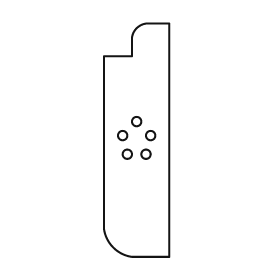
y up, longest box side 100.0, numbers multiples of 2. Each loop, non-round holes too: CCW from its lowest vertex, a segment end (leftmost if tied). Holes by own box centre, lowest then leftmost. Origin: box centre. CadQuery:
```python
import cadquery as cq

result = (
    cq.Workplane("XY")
    .moveTo(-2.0, -50.0)
    .lineTo(14.0, -50.0)
    .lineTo(14.0, 50.0)
    .lineTo(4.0, 50.0)
    .threePointArc((0.0, 48.0), (-2.0, 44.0))
    .lineTo(-2.0, 36.0)
    .lineTo(-14.0, 36.0)
    .lineTo(-14.0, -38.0)
    .threePointArc((-10.0, -46.0), (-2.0, -50.0))
    .close()
    .moveTo(-4.0, -6.0)
    .circle(2.0)
    .moveTo(4.0, -6.0)
    .circle(2.0)
    .moveTo(-6.0, 2.0)
    .circle(2.0)
    .moveTo(6.0, 2.0)
    .circle(2.0)
    .moveTo(0.0, 8.0)
    .circle(2.0)
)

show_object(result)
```